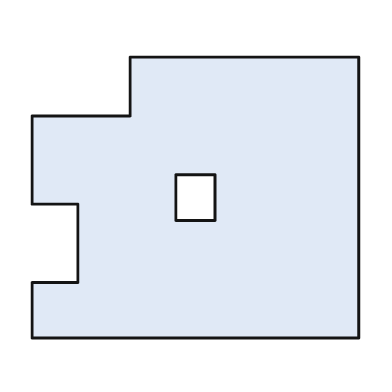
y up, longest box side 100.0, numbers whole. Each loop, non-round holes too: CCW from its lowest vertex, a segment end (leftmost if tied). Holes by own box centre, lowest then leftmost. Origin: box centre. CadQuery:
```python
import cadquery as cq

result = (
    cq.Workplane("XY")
    .moveTo(-50.0, -43.0)
    .lineTo(50.0, -43.0)
    .lineTo(50.0, 43.0)
    .lineTo(-20.0, 43.0)
    .lineTo(-20.0, 25.0)
    .lineTo(-50.0, 25.0)
    .lineTo(-50.0, -2.0)
    .lineTo(-36.0, -2.0)
    .lineTo(-36.0, -26.0)
    .lineTo(-50.0, -26.0)
    .close()
    .moveTo(-6.0, -7.0)
    .lineTo(6.0, -7.0)
    .lineTo(6.0, 7.0)
    .lineTo(-6.0, 7.0)
    .close()
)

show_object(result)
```